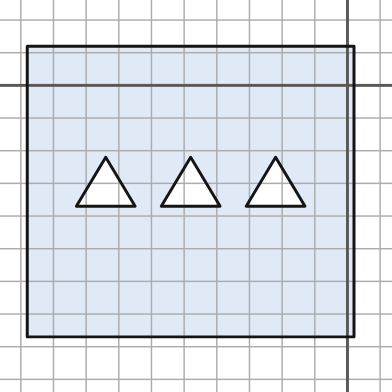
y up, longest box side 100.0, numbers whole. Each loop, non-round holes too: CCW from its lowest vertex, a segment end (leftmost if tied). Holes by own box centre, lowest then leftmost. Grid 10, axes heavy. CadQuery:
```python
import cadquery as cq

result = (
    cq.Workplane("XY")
    .moveTo(-98.0, -77.0)
    .lineTo(2.0, -77.0)
    .lineTo(2.0, 12.0)
    .lineTo(-98.0, 12.0)
    .close()
    .moveTo(-83.0, -37.0)
    .lineTo(-65.0, -37.0)
    .lineTo(-74.0, -22.0)
    .close()
    .moveTo(-57.0, -37.0)
    .lineTo(-39.0, -37.0)
    .lineTo(-48.0, -22.0)
    .close()
    .moveTo(-31.0, -37.0)
    .lineTo(-13.0, -37.0)
    .lineTo(-22.0, -22.0)
    .close()
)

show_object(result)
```